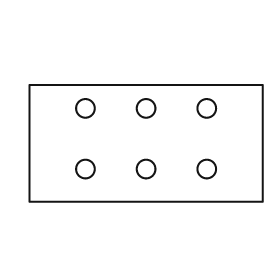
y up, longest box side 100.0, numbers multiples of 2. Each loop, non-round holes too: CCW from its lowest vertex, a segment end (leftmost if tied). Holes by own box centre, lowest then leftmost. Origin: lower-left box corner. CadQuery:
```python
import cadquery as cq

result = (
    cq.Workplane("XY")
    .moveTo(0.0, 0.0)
    .lineTo(100.0, 0.0)
    .lineTo(100.0, 50.0)
    .lineTo(0.0, 50.0)
    .close()
    .moveTo(24.0, 14.0)
    .circle(4.0)
    .moveTo(50.0, 14.0)
    .circle(4.0)
    .moveTo(76.0, 14.0)
    .circle(4.0)
    .moveTo(24.0, 40.0)
    .circle(4.0)
    .moveTo(50.0, 40.0)
    .circle(4.0)
    .moveTo(76.0, 40.0)
    .circle(4.0)
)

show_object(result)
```